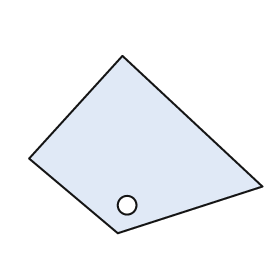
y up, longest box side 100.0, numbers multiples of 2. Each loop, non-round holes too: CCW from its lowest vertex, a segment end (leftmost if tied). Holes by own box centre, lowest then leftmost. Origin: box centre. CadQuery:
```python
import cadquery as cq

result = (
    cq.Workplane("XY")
    .moveTo(-12.0, -38.0)
    .lineTo(50.0, -18.0)
    .lineTo(-10.0, 38.0)
    .lineTo(-50.0, -6.0)
    .close()
    .moveTo(-8.0, -26.0)
    .circle(4.0)
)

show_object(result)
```